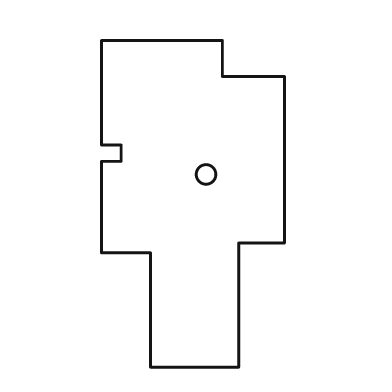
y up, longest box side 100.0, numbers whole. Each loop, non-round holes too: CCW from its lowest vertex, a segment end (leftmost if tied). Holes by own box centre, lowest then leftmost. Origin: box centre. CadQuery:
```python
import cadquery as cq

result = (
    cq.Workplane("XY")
    .moveTo(-13.0, -50.0)
    .lineTo(14.0, -50.0)
    .lineTo(14.0, -12.0)
    .lineTo(28.0, -12.0)
    .lineTo(28.0, 39.0)
    .lineTo(9.0, 39.0)
    .lineTo(9.0, 50.0)
    .lineTo(-28.0, 50.0)
    .lineTo(-28.0, 18.0)
    .lineTo(-22.0, 18.0)
    .lineTo(-22.0, 13.0)
    .lineTo(-28.0, 13.0)
    .lineTo(-28.0, -15.0)
    .lineTo(-13.0, -15.0)
    .close()
    .moveTo(4.0, 9.0)
    .circle(3.0)
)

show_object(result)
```